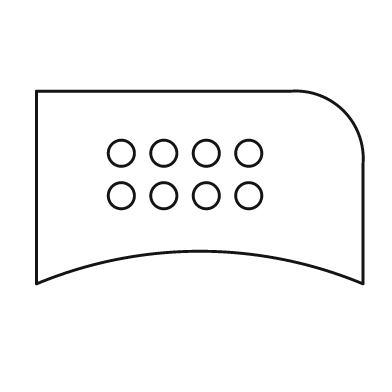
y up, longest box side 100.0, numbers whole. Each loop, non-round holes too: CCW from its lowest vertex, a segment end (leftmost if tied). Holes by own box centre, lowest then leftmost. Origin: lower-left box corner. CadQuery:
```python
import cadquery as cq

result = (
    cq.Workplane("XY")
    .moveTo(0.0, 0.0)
    .threePointArc((50.0, 10.0), (100.0, 0.0))
    .lineTo(100.0, 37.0)
    .threePointArc((94.0, 53.0), (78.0, 59.0))
    .lineTo(0.0, 59.0)
    .close()
    .moveTo(26.0, 27.0)
    .circle(4.0)
    .moveTo(39.0, 27.0)
    .circle(4.0)
    .moveTo(52.0, 27.0)
    .circle(4.0)
    .moveTo(65.0, 27.0)
    .circle(4.0)
    .moveTo(26.0, 40.0)
    .circle(4.0)
    .moveTo(39.0, 40.0)
    .circle(4.0)
    .moveTo(52.0, 40.0)
    .circle(4.0)
    .moveTo(65.0, 40.0)
    .circle(4.0)
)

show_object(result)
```